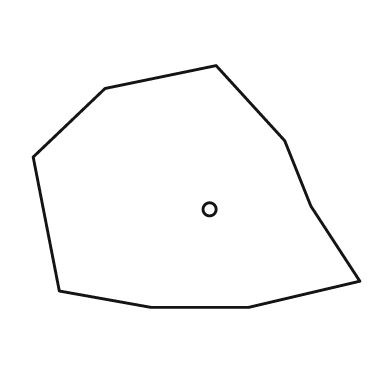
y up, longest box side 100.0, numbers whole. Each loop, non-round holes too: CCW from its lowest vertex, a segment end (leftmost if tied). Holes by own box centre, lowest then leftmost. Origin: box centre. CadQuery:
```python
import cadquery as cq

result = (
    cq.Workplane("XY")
    .moveTo(-14.0, -37.0)
    .lineTo(16.0, -37.0)
    .lineTo(50.0, -29.0)
    .lineTo(35.0, -6.0)
    .lineTo(27.0, 14.0)
    .lineTo(6.0, 37.0)
    .lineTo(-28.0, 30.0)
    .lineTo(-50.0, 9.0)
    .lineTo(-42.0, -32.0)
    .close()
    .moveTo(4.0, -7.0)
    .circle(2.0)
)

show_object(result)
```